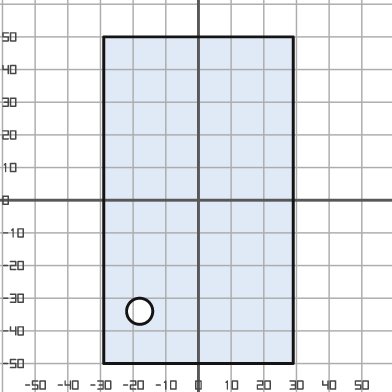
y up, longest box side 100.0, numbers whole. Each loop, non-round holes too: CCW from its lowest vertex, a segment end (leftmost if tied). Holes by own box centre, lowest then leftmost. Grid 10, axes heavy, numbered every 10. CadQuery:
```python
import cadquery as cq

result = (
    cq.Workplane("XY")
    .moveTo(-29.0, -50.0)
    .lineTo(29.0, -50.0)
    .lineTo(29.0, 50.0)
    .lineTo(-29.0, 50.0)
    .close()
    .moveTo(-18.0, -34.0)
    .circle(4.0)
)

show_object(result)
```